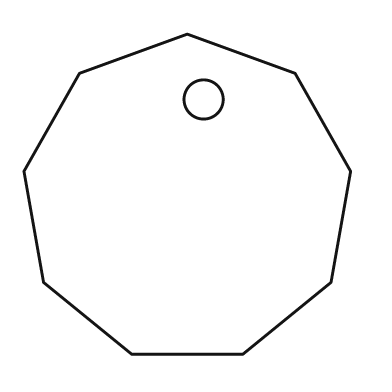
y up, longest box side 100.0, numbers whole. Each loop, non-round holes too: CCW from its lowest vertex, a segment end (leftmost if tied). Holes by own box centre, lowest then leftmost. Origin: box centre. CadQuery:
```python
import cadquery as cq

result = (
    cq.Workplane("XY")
    .moveTo(-17.0, -49.0)
    .lineTo(17.0, -49.0)
    .lineTo(44.0, -27.0)
    .lineTo(50.0, 7.0)
    .lineTo(33.0, 37.0)
    .lineTo(0.0, 49.0)
    .lineTo(-33.0, 37.0)
    .lineTo(-50.0, 7.0)
    .lineTo(-44.0, -27.0)
    .close()
    .moveTo(5.0, 29.0)
    .circle(6.0)
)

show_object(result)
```